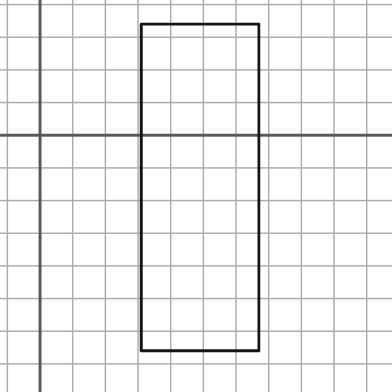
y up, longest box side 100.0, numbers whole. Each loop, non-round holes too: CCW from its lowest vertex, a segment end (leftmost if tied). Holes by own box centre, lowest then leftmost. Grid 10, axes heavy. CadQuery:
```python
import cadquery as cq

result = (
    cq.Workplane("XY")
    .moveTo(31.0, -66.0)
    .lineTo(67.0, -66.0)
    .lineTo(67.0, 34.0)
    .lineTo(31.0, 34.0)
    .close()
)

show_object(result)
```